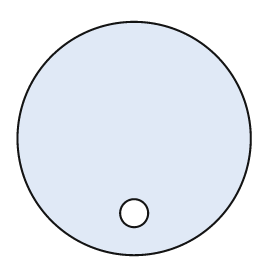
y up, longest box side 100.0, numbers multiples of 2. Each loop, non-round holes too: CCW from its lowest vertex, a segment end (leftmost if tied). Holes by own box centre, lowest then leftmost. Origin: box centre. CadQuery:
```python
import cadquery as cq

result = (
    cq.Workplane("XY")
    .moveTo(0.0, 0.0)
    .circle(50.0)
    .moveTo(0.0, -32.0)
    .circle(6.0)
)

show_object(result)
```